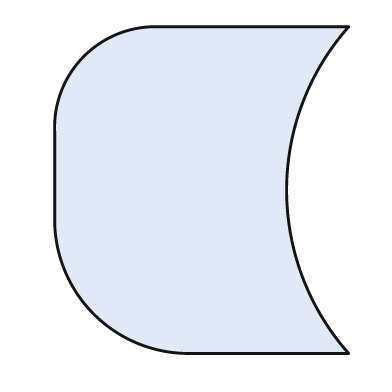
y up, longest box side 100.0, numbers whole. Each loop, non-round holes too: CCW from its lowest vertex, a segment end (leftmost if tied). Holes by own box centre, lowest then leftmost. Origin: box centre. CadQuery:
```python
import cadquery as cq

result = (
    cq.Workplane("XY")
    .moveTo(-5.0, -50.0)
    .lineTo(45.0, -50.0)
    .threePointArc((26.0, 0.0), (45.0, 50.0))
    .lineTo(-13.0, 50.0)
    .threePointArc((-36.0, 41.0), (-45.0, 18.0))
    .lineTo(-45.0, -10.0)
    .threePointArc((-33.0, -38.0), (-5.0, -50.0))
    .close()
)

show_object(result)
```